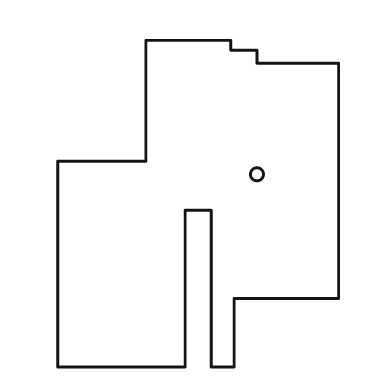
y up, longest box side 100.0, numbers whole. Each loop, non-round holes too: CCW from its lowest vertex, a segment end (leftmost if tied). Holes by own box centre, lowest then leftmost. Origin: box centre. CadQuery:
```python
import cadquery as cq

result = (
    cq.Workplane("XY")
    .moveTo(-43.0, -50.0)
    .lineTo(-4.0, -50.0)
    .lineTo(-4.0, -2.0)
    .lineTo(4.0, -2.0)
    .lineTo(4.0, -50.0)
    .lineTo(11.0, -50.0)
    .lineTo(11.0, -29.0)
    .lineTo(43.0, -29.0)
    .lineTo(43.0, 43.0)
    .lineTo(18.0, 43.0)
    .lineTo(18.0, 47.0)
    .lineTo(10.0, 47.0)
    .lineTo(10.0, 50.0)
    .lineTo(-16.0, 50.0)
    .lineTo(-16.0, 13.0)
    .lineTo(-43.0, 13.0)
    .close()
    .moveTo(18.0, 9.0)
    .circle(2.0)
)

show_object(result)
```